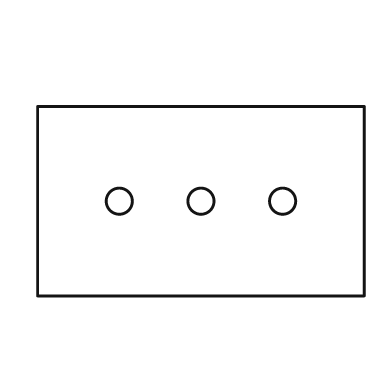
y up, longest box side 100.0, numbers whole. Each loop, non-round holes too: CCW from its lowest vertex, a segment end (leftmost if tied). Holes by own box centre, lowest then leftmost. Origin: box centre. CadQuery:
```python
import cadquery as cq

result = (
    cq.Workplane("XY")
    .moveTo(-50.0, -29.0)
    .lineTo(50.0, -29.0)
    .lineTo(50.0, 29.0)
    .lineTo(-50.0, 29.0)
    .close()
    .moveTo(-25.0, 0.0)
    .circle(4.0)
    .moveTo(0.0, 0.0)
    .circle(4.0)
    .moveTo(25.0, 0.0)
    .circle(4.0)
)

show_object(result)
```